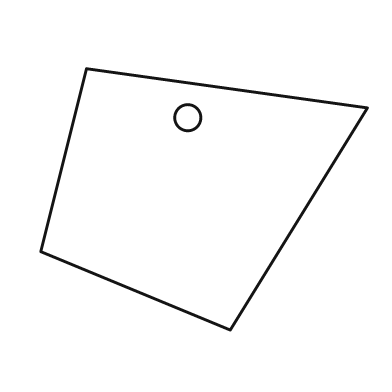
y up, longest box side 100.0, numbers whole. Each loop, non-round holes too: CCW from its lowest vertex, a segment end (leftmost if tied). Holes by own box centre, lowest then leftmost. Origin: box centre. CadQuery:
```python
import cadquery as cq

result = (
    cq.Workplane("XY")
    .moveTo(8.0, -40.0)
    .lineTo(50.0, 28.0)
    .lineTo(-36.0, 40.0)
    .lineTo(-50.0, -16.0)
    .close()
    .moveTo(-5.0, 25.0)
    .circle(4.0)
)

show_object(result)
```